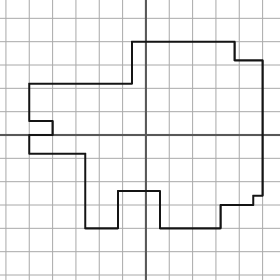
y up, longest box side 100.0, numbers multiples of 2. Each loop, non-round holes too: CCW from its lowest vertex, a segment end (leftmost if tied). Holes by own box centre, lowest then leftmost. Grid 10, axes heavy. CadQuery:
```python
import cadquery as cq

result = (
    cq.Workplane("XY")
    .moveTo(-26.0, -40.0)
    .lineTo(-12.0, -40.0)
    .lineTo(-12.0, -24.0)
    .lineTo(6.0, -24.0)
    .lineTo(6.0, -40.0)
    .lineTo(32.0, -40.0)
    .lineTo(32.0, -30.0)
    .lineTo(46.0, -30.0)
    .lineTo(46.0, -26.0)
    .lineTo(50.0, -26.0)
    .lineTo(50.0, 32.0)
    .lineTo(38.0, 32.0)
    .lineTo(38.0, 40.0)
    .lineTo(-6.0, 40.0)
    .lineTo(-6.0, 22.0)
    .lineTo(-50.0, 22.0)
    .lineTo(-50.0, 6.0)
    .lineTo(-40.0, 6.0)
    .lineTo(-40.0, 0.0)
    .lineTo(-50.0, 0.0)
    .lineTo(-50.0, -8.0)
    .lineTo(-26.0, -8.0)
    .close()
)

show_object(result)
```